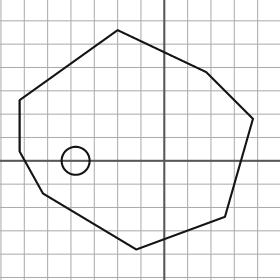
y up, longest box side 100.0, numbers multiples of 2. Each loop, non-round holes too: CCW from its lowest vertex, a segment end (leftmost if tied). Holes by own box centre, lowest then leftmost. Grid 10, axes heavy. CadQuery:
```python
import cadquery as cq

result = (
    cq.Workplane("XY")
    .moveTo(-12.0, -38.0)
    .lineTo(26.0, -24.0)
    .lineTo(38.0, 18.0)
    .lineTo(18.0, 38.0)
    .lineTo(-20.0, 56.0)
    .lineTo(-62.0, 26.0)
    .lineTo(-62.0, 4.0)
    .lineTo(-52.0, -14.0)
    .close()
    .moveTo(-38.0, 0.0)
    .circle(6.0)
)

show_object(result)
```